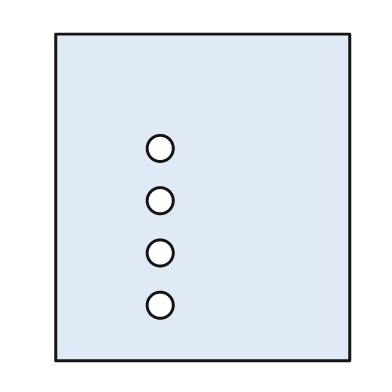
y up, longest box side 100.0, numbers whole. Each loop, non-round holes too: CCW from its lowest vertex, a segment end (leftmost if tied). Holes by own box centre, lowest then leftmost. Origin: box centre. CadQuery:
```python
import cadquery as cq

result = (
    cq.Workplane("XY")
    .moveTo(-45.0, -50.0)
    .lineTo(45.0, -50.0)
    .lineTo(45.0, 50.0)
    .lineTo(-45.0, 50.0)
    .close()
    .moveTo(-13.0, -33.0)
    .circle(4.0)
    .moveTo(-13.0, -17.0)
    .circle(4.0)
    .moveTo(-13.0, -1.0)
    .circle(4.0)
    .moveTo(-13.0, 15.0)
    .circle(4.0)
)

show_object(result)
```